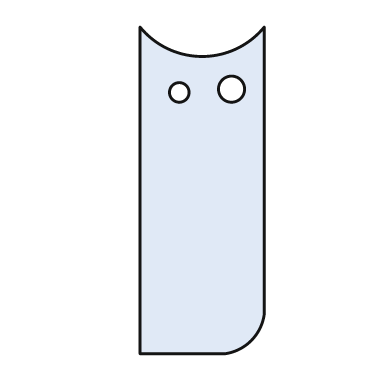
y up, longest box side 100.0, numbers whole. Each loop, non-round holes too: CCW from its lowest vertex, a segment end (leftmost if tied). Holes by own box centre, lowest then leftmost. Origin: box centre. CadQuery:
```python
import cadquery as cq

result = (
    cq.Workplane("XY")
    .moveTo(-19.0, -50.0)
    .lineTo(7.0, -50.0)
    .threePointArc((15.0, -46.0), (19.0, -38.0))
    .lineTo(19.0, 50.0)
    .threePointArc((0.0, 41.0), (-19.0, 50.0))
    .close()
    .moveTo(-7.0, 30.0)
    .circle(3.0)
    .moveTo(9.0, 31.0)
    .circle(4.0)
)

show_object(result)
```